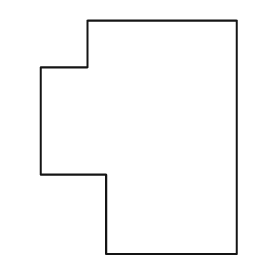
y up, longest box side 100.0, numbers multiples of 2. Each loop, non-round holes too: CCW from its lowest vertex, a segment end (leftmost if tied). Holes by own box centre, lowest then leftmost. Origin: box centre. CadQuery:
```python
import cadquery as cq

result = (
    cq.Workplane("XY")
    .moveTo(-14.0, -50.0)
    .lineTo(42.0, -50.0)
    .lineTo(42.0, 50.0)
    .lineTo(-22.0, 50.0)
    .lineTo(-22.0, 30.0)
    .lineTo(-42.0, 30.0)
    .lineTo(-42.0, -16.0)
    .lineTo(-14.0, -16.0)
    .close()
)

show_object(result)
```